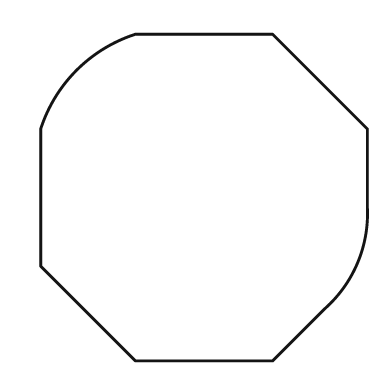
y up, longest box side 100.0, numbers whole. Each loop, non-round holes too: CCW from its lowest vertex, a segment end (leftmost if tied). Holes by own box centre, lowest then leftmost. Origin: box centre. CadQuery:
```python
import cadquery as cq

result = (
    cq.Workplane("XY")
    .moveTo(-21.0, -50.0)
    .lineTo(21.0, -50.0)
    .lineTo(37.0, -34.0)
    .threePointArc((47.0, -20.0), (50.0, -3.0))
    .lineTo(50.0, 21.0)
    .lineTo(21.0, 50.0)
    .lineTo(-21.0, 50.0)
    .threePointArc((-39.0, 39.0), (-50.0, 21.0))
    .lineTo(-50.0, -21.0)
    .close()
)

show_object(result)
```